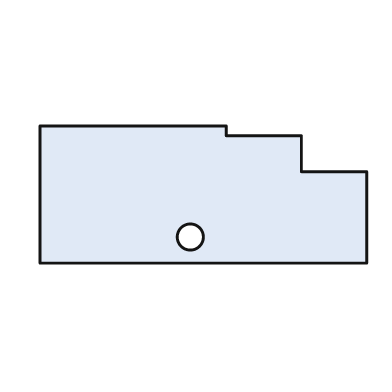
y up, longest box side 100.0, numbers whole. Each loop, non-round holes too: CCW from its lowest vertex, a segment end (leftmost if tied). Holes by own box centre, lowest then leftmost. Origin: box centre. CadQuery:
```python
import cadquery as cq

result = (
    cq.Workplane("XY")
    .moveTo(-50.0, -21.0)
    .lineTo(50.0, -21.0)
    .lineTo(50.0, 7.0)
    .lineTo(30.0, 7.0)
    .lineTo(30.0, 18.0)
    .lineTo(7.0, 18.0)
    .lineTo(7.0, 21.0)
    .lineTo(-50.0, 21.0)
    .close()
    .moveTo(-4.0, -13.0)
    .circle(4.0)
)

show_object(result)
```